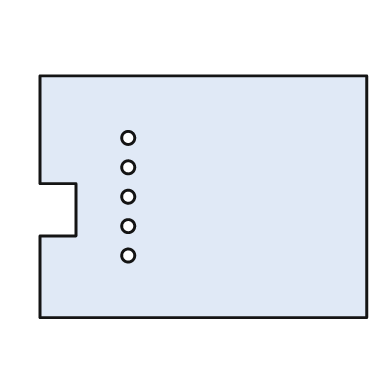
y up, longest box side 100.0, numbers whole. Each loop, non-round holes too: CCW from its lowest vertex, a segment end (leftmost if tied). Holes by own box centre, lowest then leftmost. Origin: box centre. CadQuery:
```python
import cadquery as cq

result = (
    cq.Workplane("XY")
    .moveTo(-50.0, -37.0)
    .lineTo(50.0, -37.0)
    .lineTo(50.0, 37.0)
    .lineTo(-50.0, 37.0)
    .lineTo(-50.0, 4.0)
    .lineTo(-39.0, 4.0)
    .lineTo(-39.0, -12.0)
    .lineTo(-50.0, -12.0)
    .close()
    .moveTo(-23.0, -18.0)
    .circle(2.0)
    .moveTo(-23.0, -9.0)
    .circle(2.0)
    .moveTo(-23.0, 0.0)
    .circle(2.0)
    .moveTo(-23.0, 9.0)
    .circle(2.0)
    .moveTo(-23.0, 18.0)
    .circle(2.0)
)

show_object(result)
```